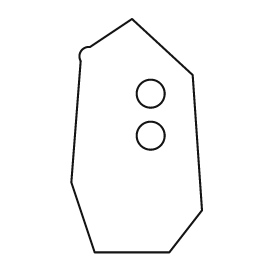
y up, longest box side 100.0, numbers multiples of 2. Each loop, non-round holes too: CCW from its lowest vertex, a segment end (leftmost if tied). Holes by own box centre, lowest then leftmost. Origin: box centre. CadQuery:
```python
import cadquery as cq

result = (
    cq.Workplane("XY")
    .moveTo(-18.0, -50.0)
    .lineTo(14.0, -50.0)
    .lineTo(28.0, -32.0)
    .lineTo(24.0, 26.0)
    .lineTo(-2.0, 50.0)
    .lineTo(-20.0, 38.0)
    .threePointArc((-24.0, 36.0), (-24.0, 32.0))
    .lineTo(-28.0, -20.0)
    .close()
    .moveTo(6.0, 0.0)
    .circle(6.0)
    .moveTo(6.0, 18.0)
    .circle(6.0)
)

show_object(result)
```